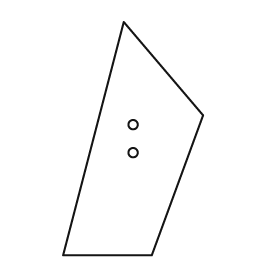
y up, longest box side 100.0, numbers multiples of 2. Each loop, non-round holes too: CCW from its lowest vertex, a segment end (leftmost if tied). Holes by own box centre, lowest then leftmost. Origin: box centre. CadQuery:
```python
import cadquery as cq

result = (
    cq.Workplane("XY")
    .moveTo(-30.0, -50.0)
    .lineTo(8.0, -50.0)
    .lineTo(30.0, 10.0)
    .lineTo(-4.0, 50.0)
    .close()
    .moveTo(0.0, -6.0)
    .circle(2.0)
    .moveTo(0.0, 6.0)
    .circle(2.0)
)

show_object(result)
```